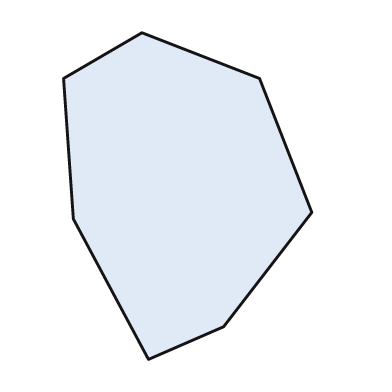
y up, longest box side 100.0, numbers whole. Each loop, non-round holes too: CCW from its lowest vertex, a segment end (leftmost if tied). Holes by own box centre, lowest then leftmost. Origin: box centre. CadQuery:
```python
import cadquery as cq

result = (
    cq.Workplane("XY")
    .moveTo(-12.0, -50.0)
    .lineTo(11.0, -40.0)
    .lineTo(38.0, -5.0)
    .lineTo(22.0, 36.0)
    .lineTo(-14.0, 50.0)
    .lineTo(-38.0, 36.0)
    .lineTo(-35.0, -7.0)
    .close()
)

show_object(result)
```